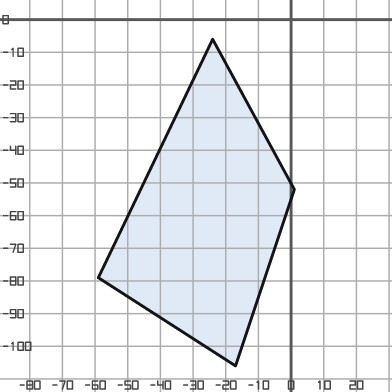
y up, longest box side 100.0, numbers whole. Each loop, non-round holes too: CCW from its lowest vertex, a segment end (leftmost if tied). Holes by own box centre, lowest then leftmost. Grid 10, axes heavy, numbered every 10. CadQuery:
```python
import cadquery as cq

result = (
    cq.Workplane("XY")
    .moveTo(-17.0, -106.0)
    .lineTo(1.0, -52.0)
    .lineTo(-24.0, -6.0)
    .lineTo(-59.0, -79.0)
    .close()
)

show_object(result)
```